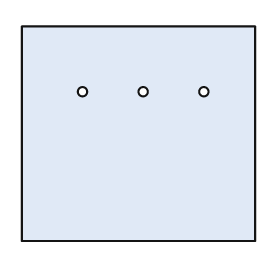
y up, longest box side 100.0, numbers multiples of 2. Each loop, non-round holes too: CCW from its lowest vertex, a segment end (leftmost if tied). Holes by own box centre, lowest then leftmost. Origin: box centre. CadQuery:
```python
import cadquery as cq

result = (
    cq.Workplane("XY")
    .moveTo(-50.0, -46.0)
    .lineTo(50.0, -46.0)
    .lineTo(50.0, 46.0)
    .lineTo(-50.0, 46.0)
    .close()
    .moveTo(-24.0, 18.0)
    .circle(2.0)
    .moveTo(2.0, 18.0)
    .circle(2.0)
    .moveTo(28.0, 18.0)
    .circle(2.0)
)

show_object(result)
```